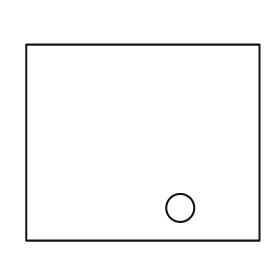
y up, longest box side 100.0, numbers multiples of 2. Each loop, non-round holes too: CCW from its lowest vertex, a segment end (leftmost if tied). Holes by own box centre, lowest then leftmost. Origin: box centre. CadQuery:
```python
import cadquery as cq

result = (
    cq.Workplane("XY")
    .moveTo(-50.0, -42.0)
    .lineTo(50.0, -42.0)
    .lineTo(50.0, 42.0)
    .lineTo(-50.0, 42.0)
    .close()
    .moveTo(16.0, -28.0)
    .circle(6.0)
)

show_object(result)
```